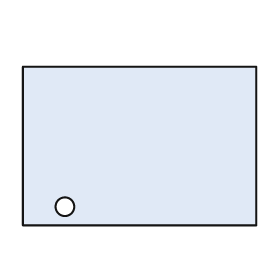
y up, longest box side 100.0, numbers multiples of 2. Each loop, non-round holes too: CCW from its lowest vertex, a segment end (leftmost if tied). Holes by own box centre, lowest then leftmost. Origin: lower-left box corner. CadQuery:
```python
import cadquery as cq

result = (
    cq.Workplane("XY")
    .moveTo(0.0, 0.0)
    .lineTo(100.0, 0.0)
    .lineTo(100.0, 68.0)
    .lineTo(0.0, 68.0)
    .close()
    .moveTo(18.0, 8.0)
    .circle(4.0)
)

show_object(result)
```